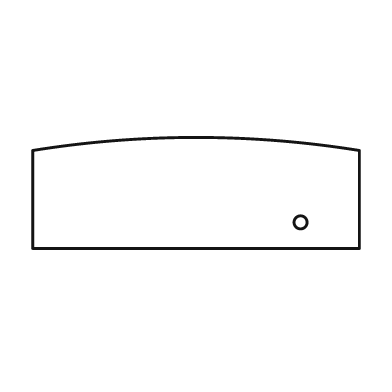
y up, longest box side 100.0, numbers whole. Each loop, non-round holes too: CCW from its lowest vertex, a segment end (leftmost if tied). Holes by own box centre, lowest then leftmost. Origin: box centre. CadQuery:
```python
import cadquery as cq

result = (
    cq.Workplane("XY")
    .moveTo(-50.0, -17.0)
    .lineTo(50.0, -17.0)
    .lineTo(50.0, 13.0)
    .threePointArc((0.0, 17.0), (-50.0, 13.0))
    .close()
    .moveTo(32.0, -9.0)
    .circle(2.0)
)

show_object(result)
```